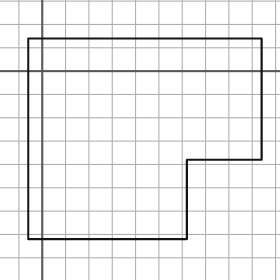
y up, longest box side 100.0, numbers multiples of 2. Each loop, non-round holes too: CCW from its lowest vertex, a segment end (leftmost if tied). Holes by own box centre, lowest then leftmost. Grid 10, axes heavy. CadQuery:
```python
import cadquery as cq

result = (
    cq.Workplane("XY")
    .moveTo(-6.0, -72.0)
    .lineTo(62.0, -72.0)
    .lineTo(62.0, -38.0)
    .lineTo(94.0, -38.0)
    .lineTo(94.0, 14.0)
    .lineTo(-6.0, 14.0)
    .close()
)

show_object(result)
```